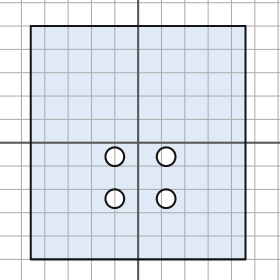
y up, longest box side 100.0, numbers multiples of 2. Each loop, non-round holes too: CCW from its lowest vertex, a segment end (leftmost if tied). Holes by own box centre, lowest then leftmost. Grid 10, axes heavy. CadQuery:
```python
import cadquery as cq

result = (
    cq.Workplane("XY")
    .moveTo(-46.0, -50.0)
    .lineTo(46.0, -50.0)
    .lineTo(46.0, 50.0)
    .lineTo(-46.0, 50.0)
    .close()
    .moveTo(-10.0, -24.0)
    .circle(4.0)
    .moveTo(12.0, -24.0)
    .circle(4.0)
    .moveTo(-10.0, -6.0)
    .circle(4.0)
    .moveTo(12.0, -6.0)
    .circle(4.0)
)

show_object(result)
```